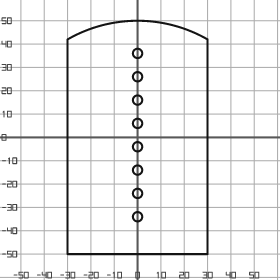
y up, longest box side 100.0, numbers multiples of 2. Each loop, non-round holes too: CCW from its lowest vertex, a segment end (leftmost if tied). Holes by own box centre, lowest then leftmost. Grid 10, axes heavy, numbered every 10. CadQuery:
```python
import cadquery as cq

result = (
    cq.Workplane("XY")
    .moveTo(-30.0, -50.0)
    .lineTo(30.0, -50.0)
    .lineTo(30.0, 42.0)
    .threePointArc((0.0, 50.0), (-30.0, 42.0))
    .close()
    .moveTo(0.0, -34.0)
    .circle(2.0)
    .moveTo(0.0, -24.0)
    .circle(2.0)
    .moveTo(0.0, -14.0)
    .circle(2.0)
    .moveTo(0.0, -4.0)
    .circle(2.0)
    .moveTo(0.0, 6.0)
    .circle(2.0)
    .moveTo(0.0, 16.0)
    .circle(2.0)
    .moveTo(0.0, 26.0)
    .circle(2.0)
    .moveTo(0.0, 36.0)
    .circle(2.0)
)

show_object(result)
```